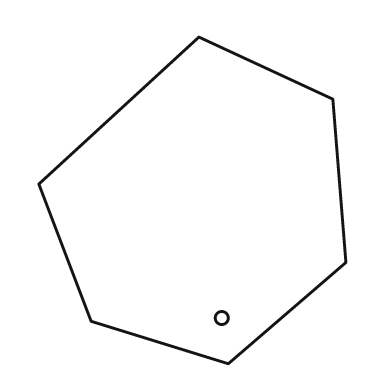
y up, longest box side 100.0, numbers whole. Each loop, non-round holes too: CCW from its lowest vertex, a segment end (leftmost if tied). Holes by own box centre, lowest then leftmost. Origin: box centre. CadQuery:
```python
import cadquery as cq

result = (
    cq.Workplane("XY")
    .moveTo(11.0, -50.0)
    .lineTo(47.0, -19.0)
    .lineTo(43.0, 31.0)
    .lineTo(2.0, 50.0)
    .lineTo(-47.0, 5.0)
    .lineTo(-31.0, -37.0)
    .close()
    .moveTo(9.0, -36.0)
    .circle(2.0)
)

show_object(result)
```